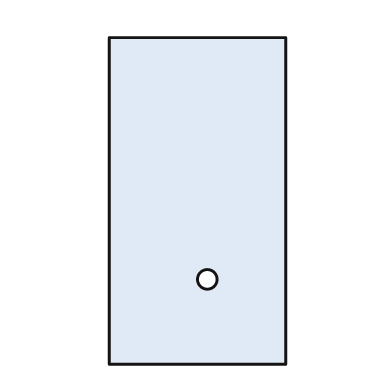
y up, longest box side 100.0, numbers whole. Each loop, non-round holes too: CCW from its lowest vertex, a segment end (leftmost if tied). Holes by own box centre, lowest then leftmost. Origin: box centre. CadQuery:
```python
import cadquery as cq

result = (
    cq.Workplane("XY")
    .moveTo(-27.0, -50.0)
    .lineTo(27.0, -50.0)
    .lineTo(27.0, 50.0)
    .lineTo(-27.0, 50.0)
    .close()
    .moveTo(3.0, -24.0)
    .circle(3.0)
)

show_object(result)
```